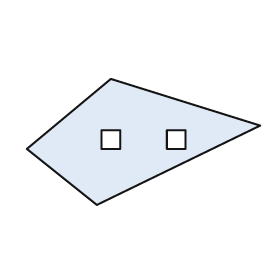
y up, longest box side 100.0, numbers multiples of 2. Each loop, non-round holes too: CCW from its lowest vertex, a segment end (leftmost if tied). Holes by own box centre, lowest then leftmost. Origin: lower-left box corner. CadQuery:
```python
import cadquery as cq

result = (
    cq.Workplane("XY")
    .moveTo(30.0, 0.0)
    .lineTo(100.0, 34.0)
    .lineTo(36.0, 54.0)
    .lineTo(0.0, 24.0)
    .close()
    .moveTo(32.0, 24.0)
    .lineTo(40.0, 24.0)
    .lineTo(40.0, 32.0)
    .lineTo(32.0, 32.0)
    .close()
    .moveTo(60.0, 24.0)
    .lineTo(68.0, 24.0)
    .lineTo(68.0, 32.0)
    .lineTo(60.0, 32.0)
    .close()
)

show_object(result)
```